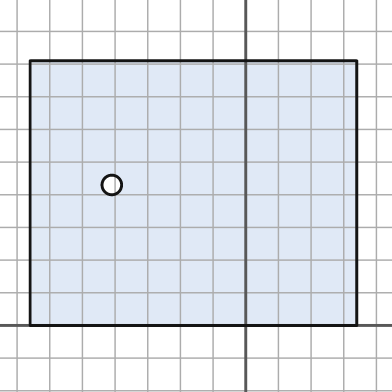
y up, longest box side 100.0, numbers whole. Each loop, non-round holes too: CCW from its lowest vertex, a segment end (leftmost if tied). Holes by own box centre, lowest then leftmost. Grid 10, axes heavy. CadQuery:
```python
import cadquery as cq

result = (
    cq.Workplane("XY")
    .moveTo(-66.0, 0.0)
    .lineTo(34.0, 0.0)
    .lineTo(34.0, 81.0)
    .lineTo(-66.0, 81.0)
    .close()
    .moveTo(-41.0, 43.0)
    .circle(3.0)
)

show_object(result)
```